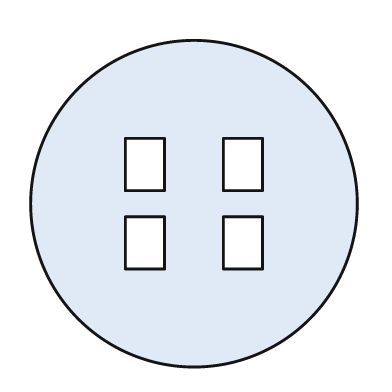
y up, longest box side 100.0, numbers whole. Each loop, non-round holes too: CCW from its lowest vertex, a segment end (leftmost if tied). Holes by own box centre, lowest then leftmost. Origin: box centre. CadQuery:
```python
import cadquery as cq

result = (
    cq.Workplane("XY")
    .moveTo(0.0, 0.0)
    .circle(50.0)
    .moveTo(-21.0, -20.0)
    .lineTo(-9.0, -20.0)
    .lineTo(-9.0, -4.0)
    .lineTo(-21.0, -4.0)
    .close()
    .moveTo(9.0, -20.0)
    .lineTo(21.0, -20.0)
    .lineTo(21.0, -4.0)
    .lineTo(9.0, -4.0)
    .close()
    .moveTo(-21.0, 4.0)
    .lineTo(-9.0, 4.0)
    .lineTo(-9.0, 20.0)
    .lineTo(-21.0, 20.0)
    .close()
    .moveTo(9.0, 4.0)
    .lineTo(21.0, 4.0)
    .lineTo(21.0, 20.0)
    .lineTo(9.0, 20.0)
    .close()
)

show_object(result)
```